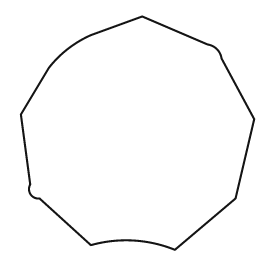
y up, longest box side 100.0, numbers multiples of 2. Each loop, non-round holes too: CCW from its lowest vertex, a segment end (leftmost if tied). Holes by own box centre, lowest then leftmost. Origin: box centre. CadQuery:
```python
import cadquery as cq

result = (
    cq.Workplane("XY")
    .moveTo(16.0, -50.0)
    .lineTo(42.0, -28.0)
    .lineTo(50.0, 6.0)
    .lineTo(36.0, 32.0)
    .threePointArc((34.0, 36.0), (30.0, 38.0))
    .lineTo(2.0, 50.0)
    .lineTo(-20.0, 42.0)
    .threePointArc((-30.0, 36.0), (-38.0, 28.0))
    .lineTo(-50.0, 8.0)
    .lineTo(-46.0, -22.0)
    .threePointArc((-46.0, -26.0), (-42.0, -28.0))
    .lineTo(-20.0, -48.0)
    .threePointArc((-2.0, -46.0), (16.0, -50.0))
    .close()
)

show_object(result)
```